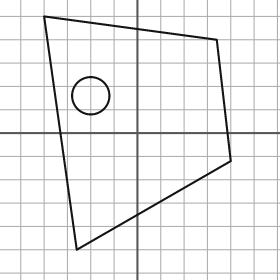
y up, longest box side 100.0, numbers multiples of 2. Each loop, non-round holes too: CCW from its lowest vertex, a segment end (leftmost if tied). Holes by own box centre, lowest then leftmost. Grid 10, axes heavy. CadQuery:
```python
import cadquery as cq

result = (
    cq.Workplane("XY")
    .moveTo(-26.0, -50.0)
    .lineTo(40.0, -12.0)
    .lineTo(34.0, 40.0)
    .lineTo(-40.0, 50.0)
    .close()
    .moveTo(-20.0, 16.0)
    .circle(8.0)
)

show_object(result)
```